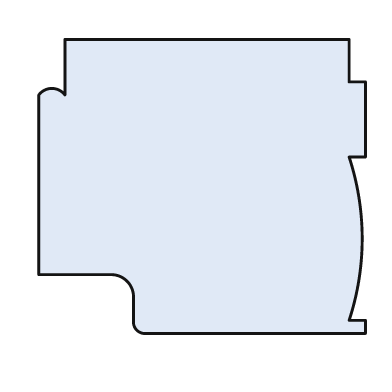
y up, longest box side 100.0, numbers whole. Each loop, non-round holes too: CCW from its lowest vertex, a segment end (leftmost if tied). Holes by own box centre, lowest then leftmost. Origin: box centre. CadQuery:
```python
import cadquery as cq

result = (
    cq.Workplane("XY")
    .moveTo(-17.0, -45.0)
    .lineTo(50.0, -45.0)
    .lineTo(50.0, -41.0)
    .lineTo(45.0, -41.0)
    .threePointArc((49.0, -16.0), (45.0, 9.0))
    .lineTo(50.0, 9.0)
    .lineTo(50.0, 32.0)
    .lineTo(45.0, 32.0)
    .lineTo(45.0, 45.0)
    .lineTo(-42.0, 45.0)
    .lineTo(-42.0, 28.0)
    .threePointArc((-46.0, 30.0), (-50.0, 28.0))
    .lineTo(-50.0, -27.0)
    .lineTo(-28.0, -27.0)
    .threePointArc((-23.0, -29.0), (-21.0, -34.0))
    .lineTo(-21.0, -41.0)
    .threePointArc((-20.0, -44.0), (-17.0, -45.0))
    .close()
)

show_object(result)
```